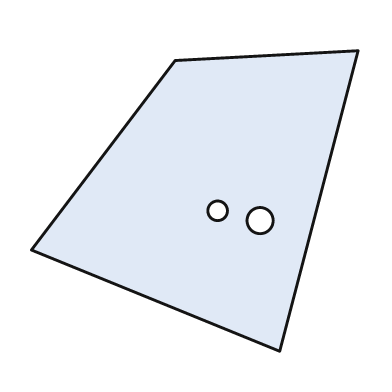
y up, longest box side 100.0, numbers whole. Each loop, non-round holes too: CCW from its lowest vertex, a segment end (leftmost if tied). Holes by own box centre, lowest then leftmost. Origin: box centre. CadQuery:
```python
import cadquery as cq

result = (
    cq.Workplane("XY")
    .moveTo(26.0, -46.0)
    .lineTo(50.0, 46.0)
    .lineTo(-6.0, 43.0)
    .lineTo(-50.0, -15.0)
    .close()
    .moveTo(20.0, -6.0)
    .circle(4.0)
    .moveTo(7.0, -3.0)
    .circle(3.0)
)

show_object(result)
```